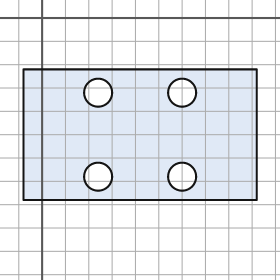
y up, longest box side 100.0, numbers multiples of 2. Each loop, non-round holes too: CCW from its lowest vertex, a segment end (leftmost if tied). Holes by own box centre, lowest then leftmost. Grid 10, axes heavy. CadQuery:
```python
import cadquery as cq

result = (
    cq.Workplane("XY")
    .moveTo(-8.0, -78.0)
    .lineTo(92.0, -78.0)
    .lineTo(92.0, -22.0)
    .lineTo(-8.0, -22.0)
    .close()
    .moveTo(24.0, -68.0)
    .circle(6.0)
    .moveTo(60.0, -68.0)
    .circle(6.0)
    .moveTo(24.0, -32.0)
    .circle(6.0)
    .moveTo(60.0, -32.0)
    .circle(6.0)
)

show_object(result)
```